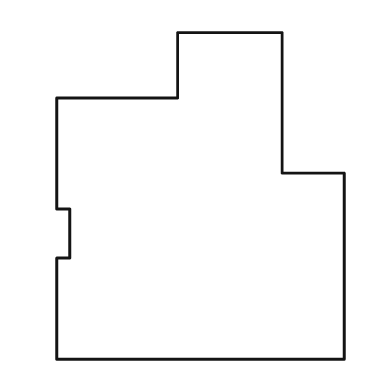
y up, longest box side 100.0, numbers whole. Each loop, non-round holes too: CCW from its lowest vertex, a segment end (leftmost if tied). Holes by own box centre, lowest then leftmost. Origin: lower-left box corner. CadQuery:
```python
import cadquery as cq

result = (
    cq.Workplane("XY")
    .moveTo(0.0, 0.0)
    .lineTo(88.0, 0.0)
    .lineTo(88.0, 57.0)
    .lineTo(69.0, 57.0)
    .lineTo(69.0, 100.0)
    .lineTo(37.0, 100.0)
    .lineTo(37.0, 80.0)
    .lineTo(0.0, 80.0)
    .lineTo(0.0, 46.0)
    .lineTo(4.0, 46.0)
    .lineTo(4.0, 31.0)
    .lineTo(0.0, 31.0)
    .close()
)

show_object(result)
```